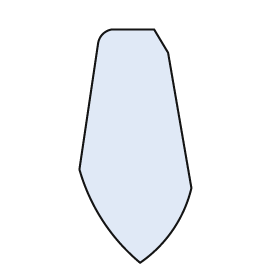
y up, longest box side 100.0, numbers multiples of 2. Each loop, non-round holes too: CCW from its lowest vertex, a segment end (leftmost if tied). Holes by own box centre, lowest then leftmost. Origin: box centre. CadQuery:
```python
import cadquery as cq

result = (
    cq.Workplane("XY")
    .moveTo(2.0, -50.0)
    .threePointArc((16.0, -36.0), (24.0, -18.0))
    .lineTo(14.0, 40.0)
    .lineTo(8.0, 50.0)
    .lineTo(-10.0, 50.0)
    .threePointArc((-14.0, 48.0), (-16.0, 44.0))
    .lineTo(-24.0, -10.0)
    .threePointArc((-14.0, -32.0), (2.0, -50.0))
    .close()
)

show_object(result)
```